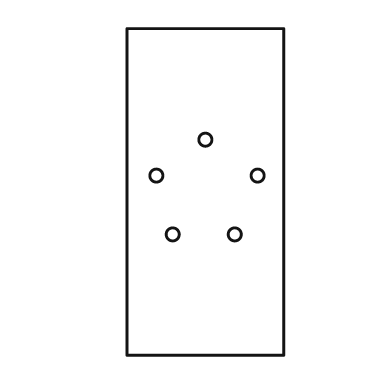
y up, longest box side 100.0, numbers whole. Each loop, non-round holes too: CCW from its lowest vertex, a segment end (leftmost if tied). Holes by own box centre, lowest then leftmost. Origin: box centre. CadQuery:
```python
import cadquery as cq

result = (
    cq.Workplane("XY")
    .moveTo(-24.0, -50.0)
    .lineTo(24.0, -50.0)
    .lineTo(24.0, 50.0)
    .lineTo(-24.0, 50.0)
    .close()
    .moveTo(-10.0, -13.0)
    .circle(2.0)
    .moveTo(9.0, -13.0)
    .circle(2.0)
    .moveTo(-15.0, 5.0)
    .circle(2.0)
    .moveTo(16.0, 5.0)
    .circle(2.0)
    .moveTo(0.0, 16.0)
    .circle(2.0)
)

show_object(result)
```